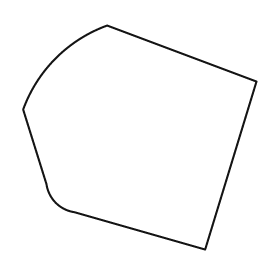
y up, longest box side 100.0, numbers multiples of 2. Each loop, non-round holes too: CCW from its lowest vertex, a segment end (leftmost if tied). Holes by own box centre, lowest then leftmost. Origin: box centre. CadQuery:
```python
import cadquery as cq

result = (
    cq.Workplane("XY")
    .moveTo(28.0, -48.0)
    .lineTo(50.0, 24.0)
    .lineTo(-14.0, 48.0)
    .threePointArc((-36.0, 34.0), (-50.0, 12.0))
    .lineTo(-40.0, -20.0)
    .threePointArc((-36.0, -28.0), (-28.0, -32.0))
    .close()
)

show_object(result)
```